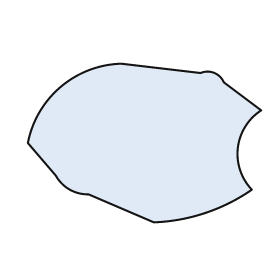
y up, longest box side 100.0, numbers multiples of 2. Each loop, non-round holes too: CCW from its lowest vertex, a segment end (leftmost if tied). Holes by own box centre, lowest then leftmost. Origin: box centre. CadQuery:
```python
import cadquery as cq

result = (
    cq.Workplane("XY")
    .moveTo(4.0, -34.0)
    .threePointArc((26.0, -30.0), (46.0, -20.0))
    .threePointArc((40.0, -2.0), (50.0, 14.0))
    .lineTo(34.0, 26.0)
    .threePointArc((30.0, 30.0), (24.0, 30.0))
    .lineTo(-10.0, 34.0)
    .threePointArc((-36.0, 24.0), (-50.0, 0.0))
    .lineTo(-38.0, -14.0)
    .threePointArc((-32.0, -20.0), (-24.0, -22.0))
    .close()
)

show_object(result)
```